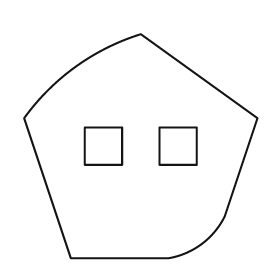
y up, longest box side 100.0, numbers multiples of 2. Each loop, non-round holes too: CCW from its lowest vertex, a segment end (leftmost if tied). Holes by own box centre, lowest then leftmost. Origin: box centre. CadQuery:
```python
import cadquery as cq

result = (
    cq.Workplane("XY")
    .moveTo(-30.0, -48.0)
    .lineTo(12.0, -48.0)
    .threePointArc((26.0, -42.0), (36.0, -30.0))
    .lineTo(50.0, 12.0)
    .lineTo(0.0, 48.0)
    .threePointArc((-28.0, 34.0), (-50.0, 12.0))
    .close()
    .moveTo(-24.0, -8.0)
    .lineTo(-8.0, -8.0)
    .lineTo(-8.0, 8.0)
    .lineTo(-24.0, 8.0)
    .close()
    .moveTo(8.0, -8.0)
    .lineTo(24.0, -8.0)
    .lineTo(24.0, 8.0)
    .lineTo(8.0, 8.0)
    .close()
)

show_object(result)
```